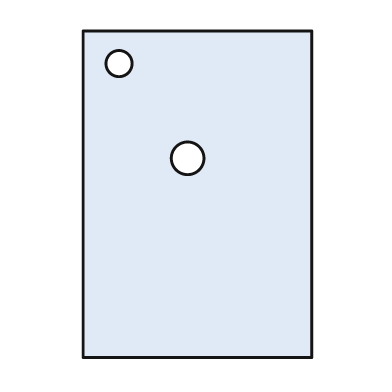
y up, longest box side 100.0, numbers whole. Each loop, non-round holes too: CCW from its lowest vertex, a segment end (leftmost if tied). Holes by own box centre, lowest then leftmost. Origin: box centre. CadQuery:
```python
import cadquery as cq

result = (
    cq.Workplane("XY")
    .moveTo(-35.0, -50.0)
    .lineTo(35.0, -50.0)
    .lineTo(35.0, 50.0)
    .lineTo(-35.0, 50.0)
    .close()
    .moveTo(-3.0, 11.0)
    .circle(5.0)
    .moveTo(-24.0, 40.0)
    .circle(4.0)
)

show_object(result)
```